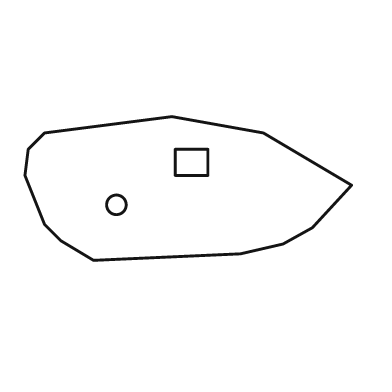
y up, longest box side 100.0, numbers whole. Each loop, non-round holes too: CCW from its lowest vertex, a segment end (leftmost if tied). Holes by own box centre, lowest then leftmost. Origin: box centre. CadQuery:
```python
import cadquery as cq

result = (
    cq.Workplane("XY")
    .moveTo(-29.0, -22.0)
    .lineTo(16.0, -20.0)
    .lineTo(29.0, -17.0)
    .lineTo(38.0, -12.0)
    .lineTo(50.0, 1.0)
    .lineTo(23.0, 17.0)
    .lineTo(-5.0, 22.0)
    .lineTo(-44.0, 17.0)
    .lineTo(-49.0, 12.0)
    .lineTo(-50.0, 4.0)
    .lineTo(-44.0, -11.0)
    .lineTo(-39.0, -16.0)
    .close()
    .moveTo(-22.0, -5.0)
    .circle(3.0)
    .moveTo(-4.0, 4.0)
    .lineTo(6.0, 4.0)
    .lineTo(6.0, 12.0)
    .lineTo(-4.0, 12.0)
    .close()
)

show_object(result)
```